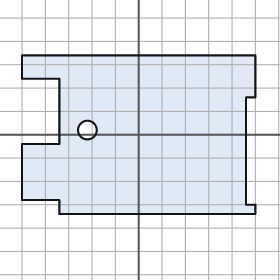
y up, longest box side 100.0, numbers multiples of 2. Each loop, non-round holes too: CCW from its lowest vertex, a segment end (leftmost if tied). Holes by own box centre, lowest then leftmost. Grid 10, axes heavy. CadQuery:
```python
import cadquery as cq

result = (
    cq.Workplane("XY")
    .moveTo(-34.0, -34.0)
    .lineTo(50.0, -34.0)
    .lineTo(50.0, -30.0)
    .lineTo(46.0, -30.0)
    .lineTo(46.0, 16.0)
    .lineTo(50.0, 16.0)
    .lineTo(50.0, 34.0)
    .lineTo(-50.0, 34.0)
    .lineTo(-50.0, 24.0)
    .lineTo(-34.0, 24.0)
    .lineTo(-34.0, -4.0)
    .lineTo(-50.0, -4.0)
    .lineTo(-50.0, -28.0)
    .lineTo(-34.0, -28.0)
    .close()
    .moveTo(-22.0, 2.0)
    .circle(4.0)
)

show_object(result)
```